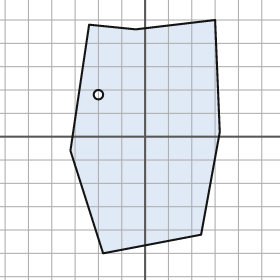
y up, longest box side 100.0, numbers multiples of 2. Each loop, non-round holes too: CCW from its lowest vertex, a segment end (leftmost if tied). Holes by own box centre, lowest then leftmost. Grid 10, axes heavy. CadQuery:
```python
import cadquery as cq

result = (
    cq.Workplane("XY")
    .moveTo(-18.0, -50.0)
    .lineTo(24.0, -42.0)
    .lineTo(32.0, 2.0)
    .lineTo(30.0, 50.0)
    .lineTo(-4.0, 46.0)
    .lineTo(-24.0, 48.0)
    .lineTo(-32.0, -6.0)
    .close()
    .moveTo(-20.0, 18.0)
    .circle(2.0)
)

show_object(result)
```